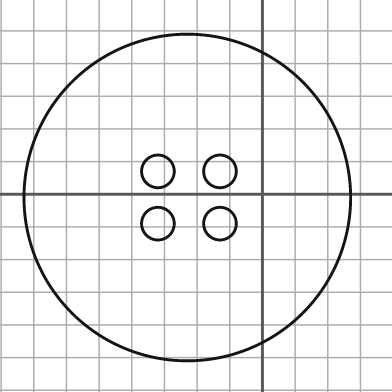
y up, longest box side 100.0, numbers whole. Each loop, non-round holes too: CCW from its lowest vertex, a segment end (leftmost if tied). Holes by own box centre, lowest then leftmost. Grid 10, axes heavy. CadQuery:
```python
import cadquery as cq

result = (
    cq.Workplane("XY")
    .moveTo(-23.0, -1.0)
    .circle(50.0)
    .moveTo(-32.0, -9.0)
    .circle(5.0)
    .moveTo(-13.0, -9.0)
    .circle(5.0)
    .moveTo(-32.0, 7.0)
    .circle(5.0)
    .moveTo(-13.0, 7.0)
    .circle(5.0)
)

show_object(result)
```